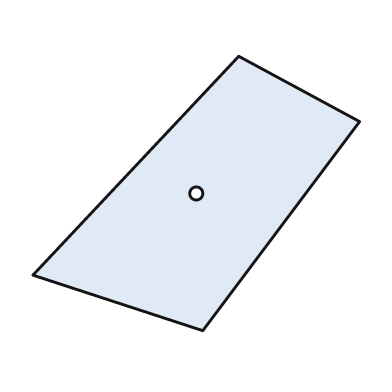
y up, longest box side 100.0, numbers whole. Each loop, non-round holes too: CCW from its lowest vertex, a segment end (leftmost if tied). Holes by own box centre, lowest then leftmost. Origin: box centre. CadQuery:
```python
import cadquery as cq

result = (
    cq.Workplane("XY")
    .moveTo(2.0, -42.0)
    .lineTo(50.0, 22.0)
    .lineTo(13.0, 42.0)
    .lineTo(-50.0, -25.0)
    .close()
    .moveTo(0.0, 0.0)
    .circle(2.0)
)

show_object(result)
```